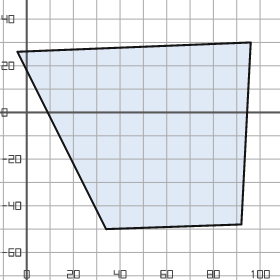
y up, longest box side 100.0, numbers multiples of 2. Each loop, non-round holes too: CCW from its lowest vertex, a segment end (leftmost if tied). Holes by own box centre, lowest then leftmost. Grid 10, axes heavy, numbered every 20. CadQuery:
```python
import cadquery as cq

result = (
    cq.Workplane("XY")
    .moveTo(34.0, -50.0)
    .lineTo(92.0, -48.0)
    .lineTo(96.0, 30.0)
    .lineTo(-4.0, 26.0)
    .close()
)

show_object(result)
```